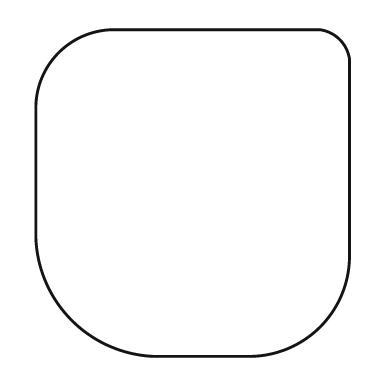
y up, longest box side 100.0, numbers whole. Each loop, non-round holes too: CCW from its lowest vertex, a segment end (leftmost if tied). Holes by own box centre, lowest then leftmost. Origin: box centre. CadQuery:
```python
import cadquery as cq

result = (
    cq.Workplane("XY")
    .moveTo(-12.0, -50.0)
    .lineTo(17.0, -50.0)
    .threePointArc((39.0, -41.0), (48.0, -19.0))
    .lineTo(48.0, 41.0)
    .threePointArc((45.0, 47.0), (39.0, 50.0))
    .lineTo(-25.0, 50.0)
    .threePointArc((-41.0, 43.0), (-48.0, 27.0))
    .lineTo(-48.0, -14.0)
    .threePointArc((-37.0, -39.0), (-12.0, -50.0))
    .close()
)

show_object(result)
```